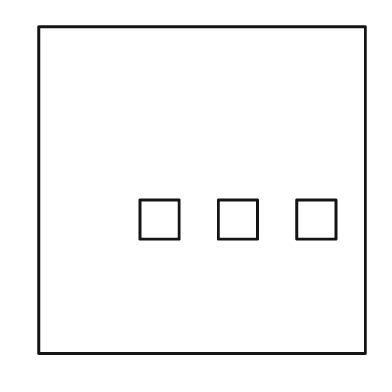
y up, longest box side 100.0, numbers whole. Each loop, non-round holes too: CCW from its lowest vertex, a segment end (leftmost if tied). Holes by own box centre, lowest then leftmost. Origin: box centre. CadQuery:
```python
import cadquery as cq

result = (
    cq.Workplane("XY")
    .moveTo(-50.0, -50.0)
    .lineTo(50.0, -50.0)
    .lineTo(50.0, 50.0)
    .lineTo(-50.0, 50.0)
    .close()
    .moveTo(-19.0, -15.0)
    .lineTo(-7.0, -15.0)
    .lineTo(-7.0, -3.0)
    .lineTo(-19.0, -3.0)
    .close()
    .moveTo(5.0, -15.0)
    .lineTo(17.0, -15.0)
    .lineTo(17.0, -3.0)
    .lineTo(5.0, -3.0)
    .close()
    .moveTo(29.0, -15.0)
    .lineTo(41.0, -15.0)
    .lineTo(41.0, -3.0)
    .lineTo(29.0, -3.0)
    .close()
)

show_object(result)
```